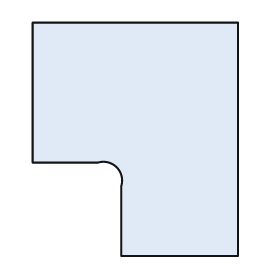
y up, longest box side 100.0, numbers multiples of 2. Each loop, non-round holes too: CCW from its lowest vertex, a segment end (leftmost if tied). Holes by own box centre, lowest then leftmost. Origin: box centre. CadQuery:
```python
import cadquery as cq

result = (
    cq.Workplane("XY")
    .moveTo(-6.0, -50.0)
    .lineTo(44.0, -50.0)
    .lineTo(44.0, 50.0)
    .lineTo(-44.0, 50.0)
    .lineTo(-44.0, -10.0)
    .lineTo(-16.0, -10.0)
    .threePointArc((-8.0, -12.0), (-6.0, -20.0))
    .close()
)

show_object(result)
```